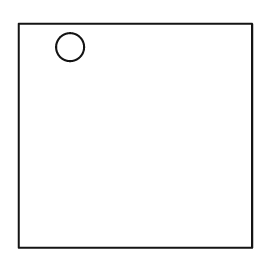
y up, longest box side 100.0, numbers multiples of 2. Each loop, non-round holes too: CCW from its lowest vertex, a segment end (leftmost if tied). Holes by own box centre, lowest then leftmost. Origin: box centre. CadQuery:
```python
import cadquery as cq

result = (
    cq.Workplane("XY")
    .moveTo(-50.0, -48.0)
    .lineTo(50.0, -48.0)
    .lineTo(50.0, 48.0)
    .lineTo(-50.0, 48.0)
    .close()
    .moveTo(-28.0, 38.0)
    .circle(6.0)
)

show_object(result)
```